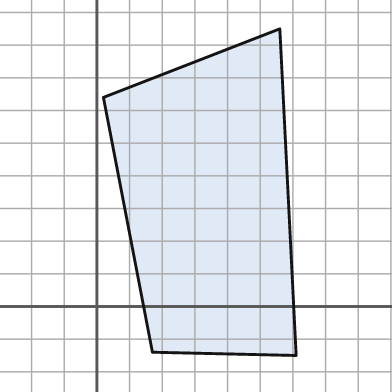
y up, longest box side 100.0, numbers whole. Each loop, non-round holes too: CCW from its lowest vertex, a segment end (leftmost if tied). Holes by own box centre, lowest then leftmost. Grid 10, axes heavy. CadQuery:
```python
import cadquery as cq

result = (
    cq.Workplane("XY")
    .moveTo(61.0, -15.0)
    .lineTo(56.0, 85.0)
    .lineTo(2.0, 64.0)
    .lineTo(17.0, -14.0)
    .close()
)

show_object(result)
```